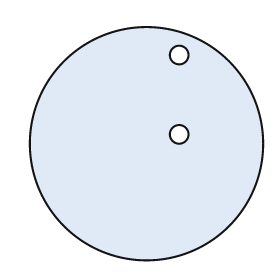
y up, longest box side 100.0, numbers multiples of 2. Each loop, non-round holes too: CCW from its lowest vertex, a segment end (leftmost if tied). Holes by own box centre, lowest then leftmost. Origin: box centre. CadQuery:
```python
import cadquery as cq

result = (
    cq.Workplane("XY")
    .moveTo(0.0, 0.0)
    .circle(50.0)
    .moveTo(14.0, 4.0)
    .circle(4.0)
    .moveTo(14.0, 38.0)
    .circle(4.0)
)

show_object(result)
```